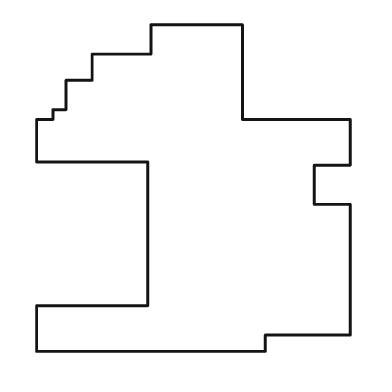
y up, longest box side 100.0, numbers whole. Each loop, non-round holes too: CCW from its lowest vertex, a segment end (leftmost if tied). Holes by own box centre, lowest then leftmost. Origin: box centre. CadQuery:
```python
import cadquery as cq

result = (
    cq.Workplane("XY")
    .moveTo(-48.0, -50.0)
    .lineTo(22.0, -50.0)
    .lineTo(22.0, -45.0)
    .lineTo(48.0, -45.0)
    .lineTo(48.0, -5.0)
    .lineTo(37.0, -5.0)
    .lineTo(37.0, 7.0)
    .lineTo(48.0, 7.0)
    .lineTo(48.0, 21.0)
    .lineTo(15.0, 21.0)
    .lineTo(15.0, 50.0)
    .lineTo(-13.0, 50.0)
    .lineTo(-13.0, 41.0)
    .lineTo(-31.0, 41.0)
    .lineTo(-31.0, 33.0)
    .lineTo(-39.0, 33.0)
    .lineTo(-39.0, 24.0)
    .lineTo(-43.0, 24.0)
    .lineTo(-43.0, 21.0)
    .lineTo(-48.0, 21.0)
    .lineTo(-48.0, 8.0)
    .lineTo(-14.0, 8.0)
    .lineTo(-14.0, -36.0)
    .lineTo(-48.0, -36.0)
    .close()
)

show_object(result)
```